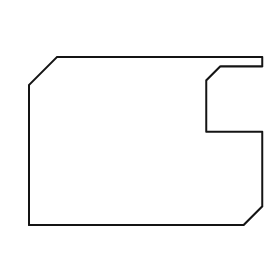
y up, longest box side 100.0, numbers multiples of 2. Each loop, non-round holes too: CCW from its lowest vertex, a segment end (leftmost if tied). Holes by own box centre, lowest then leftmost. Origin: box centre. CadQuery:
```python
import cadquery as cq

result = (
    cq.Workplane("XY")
    .moveTo(-50.0, -36.0)
    .lineTo(42.0, -36.0)
    .lineTo(50.0, -28.0)
    .lineTo(50.0, 4.0)
    .lineTo(26.0, 4.0)
    .lineTo(26.0, 26.0)
    .lineTo(32.0, 32.0)
    .lineTo(50.0, 32.0)
    .lineTo(50.0, 36.0)
    .lineTo(-38.0, 36.0)
    .lineTo(-50.0, 24.0)
    .close()
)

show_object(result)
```